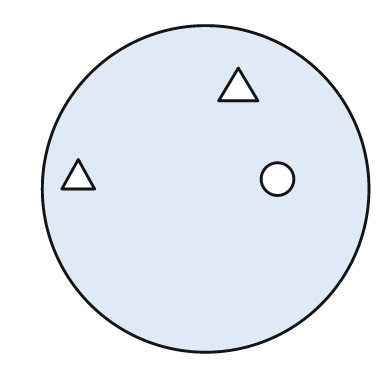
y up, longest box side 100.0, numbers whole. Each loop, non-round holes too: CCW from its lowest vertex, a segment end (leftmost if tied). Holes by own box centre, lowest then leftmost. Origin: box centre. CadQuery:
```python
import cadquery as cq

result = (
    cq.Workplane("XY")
    .moveTo(0.0, 0.0)
    .circle(50.0)
    .moveTo(22.0, 3.0)
    .circle(5.0)
    .moveTo(-44.0, 0.0)
    .lineTo(-34.0, 0.0)
    .lineTo(-39.0, 9.0)
    .close()
    .moveTo(4.0, 27.0)
    .lineTo(16.0, 27.0)
    .lineTo(10.0, 37.0)
    .close()
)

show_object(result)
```